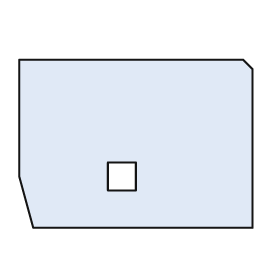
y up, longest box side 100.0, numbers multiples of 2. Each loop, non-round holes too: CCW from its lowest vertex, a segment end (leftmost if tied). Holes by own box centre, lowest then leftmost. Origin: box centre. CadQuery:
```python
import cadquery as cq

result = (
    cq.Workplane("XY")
    .moveTo(-44.0, -36.0)
    .lineTo(50.0, -36.0)
    .lineTo(50.0, 32.0)
    .lineTo(46.0, 36.0)
    .lineTo(-50.0, 36.0)
    .lineTo(-50.0, -14.0)
    .close()
    .moveTo(-12.0, -20.0)
    .lineTo(0.0, -20.0)
    .lineTo(0.0, -8.0)
    .lineTo(-12.0, -8.0)
    .close()
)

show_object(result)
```